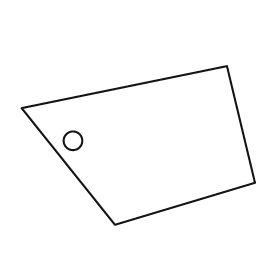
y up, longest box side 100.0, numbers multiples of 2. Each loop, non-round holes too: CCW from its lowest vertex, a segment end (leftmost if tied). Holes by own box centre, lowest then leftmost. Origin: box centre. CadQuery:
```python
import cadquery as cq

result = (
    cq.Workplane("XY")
    .moveTo(-10.0, -34.0)
    .lineTo(50.0, -16.0)
    .lineTo(38.0, 34.0)
    .lineTo(-50.0, 16.0)
    .close()
    .moveTo(-28.0, 2.0)
    .circle(4.0)
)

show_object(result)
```